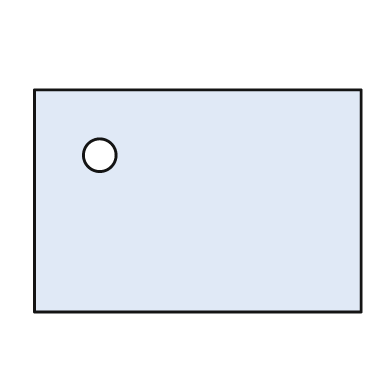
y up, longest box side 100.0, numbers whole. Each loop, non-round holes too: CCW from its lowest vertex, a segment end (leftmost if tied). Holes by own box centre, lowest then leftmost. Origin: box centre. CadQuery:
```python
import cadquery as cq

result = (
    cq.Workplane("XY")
    .moveTo(-50.0, -34.0)
    .lineTo(50.0, -34.0)
    .lineTo(50.0, 34.0)
    .lineTo(-50.0, 34.0)
    .close()
    .moveTo(-30.0, 14.0)
    .circle(5.0)
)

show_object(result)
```